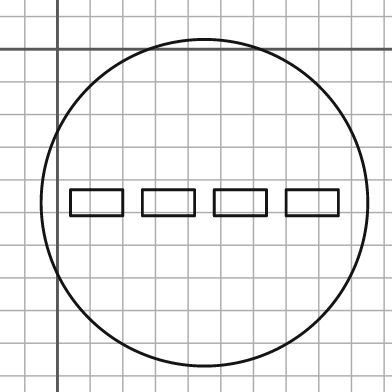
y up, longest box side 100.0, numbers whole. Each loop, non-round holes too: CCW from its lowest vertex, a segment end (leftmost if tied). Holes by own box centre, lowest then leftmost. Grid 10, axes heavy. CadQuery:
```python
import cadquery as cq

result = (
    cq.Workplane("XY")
    .moveTo(45.0, -47.0)
    .circle(50.0)
    .moveTo(4.0, -51.0)
    .lineTo(20.0, -51.0)
    .lineTo(20.0, -43.0)
    .lineTo(4.0, -43.0)
    .close()
    .moveTo(26.0, -51.0)
    .lineTo(42.0, -51.0)
    .lineTo(42.0, -43.0)
    .lineTo(26.0, -43.0)
    .close()
    .moveTo(48.0, -51.0)
    .lineTo(64.0, -51.0)
    .lineTo(64.0, -43.0)
    .lineTo(48.0, -43.0)
    .close()
    .moveTo(70.0, -51.0)
    .lineTo(86.0, -51.0)
    .lineTo(86.0, -43.0)
    .lineTo(70.0, -43.0)
    .close()
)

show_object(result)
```